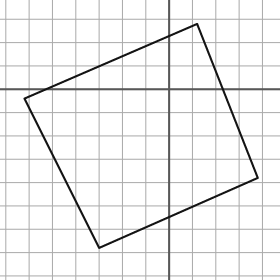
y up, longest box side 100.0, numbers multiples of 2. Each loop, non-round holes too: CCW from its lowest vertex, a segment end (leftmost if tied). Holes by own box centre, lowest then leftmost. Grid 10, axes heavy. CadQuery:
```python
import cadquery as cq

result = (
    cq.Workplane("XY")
    .moveTo(-30.0, -68.0)
    .lineTo(38.0, -38.0)
    .lineTo(12.0, 28.0)
    .lineTo(-62.0, -4.0)
    .close()
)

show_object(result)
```